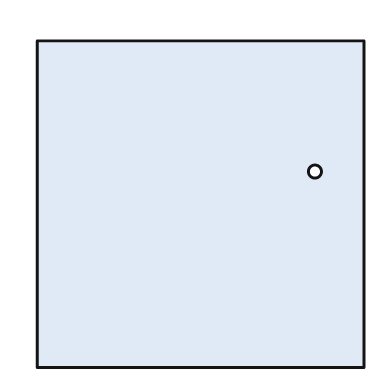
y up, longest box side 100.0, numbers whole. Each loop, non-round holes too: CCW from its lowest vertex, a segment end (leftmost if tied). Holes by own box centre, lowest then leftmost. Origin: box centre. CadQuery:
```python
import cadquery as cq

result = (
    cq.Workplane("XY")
    .moveTo(-50.0, -50.0)
    .lineTo(50.0, -50.0)
    .lineTo(50.0, 50.0)
    .lineTo(-50.0, 50.0)
    .close()
    .moveTo(35.0, 10.0)
    .circle(2.0)
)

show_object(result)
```